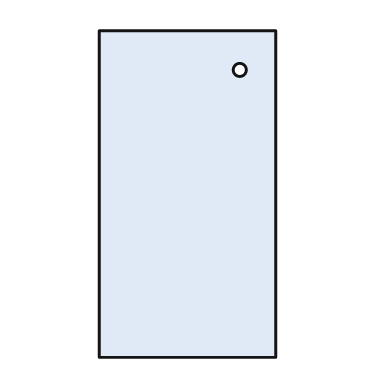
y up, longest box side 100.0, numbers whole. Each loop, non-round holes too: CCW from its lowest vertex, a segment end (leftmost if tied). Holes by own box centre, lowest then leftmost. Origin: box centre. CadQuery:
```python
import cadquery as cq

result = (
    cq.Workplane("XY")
    .moveTo(-27.0, -50.0)
    .lineTo(27.0, -50.0)
    .lineTo(27.0, 50.0)
    .lineTo(-27.0, 50.0)
    .close()
    .moveTo(16.0, 38.0)
    .circle(2.0)
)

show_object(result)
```